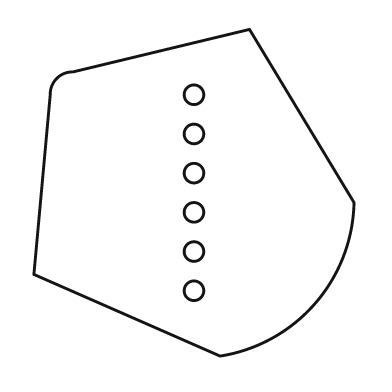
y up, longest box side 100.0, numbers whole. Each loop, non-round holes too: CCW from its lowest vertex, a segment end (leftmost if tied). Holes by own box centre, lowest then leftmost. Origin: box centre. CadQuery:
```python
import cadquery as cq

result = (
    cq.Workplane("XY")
    .moveTo(8.0, -50.0)
    .threePointArc((37.0, -34.0), (49.0, -3.0))
    .lineTo(17.0, 50.0)
    .lineTo(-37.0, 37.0)
    .threePointArc((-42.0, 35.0), (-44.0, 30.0))
    .lineTo(-49.0, -25.0)
    .close()
    .moveTo(0.0, -30.0)
    .circle(3.0)
    .moveTo(0.0, -18.0)
    .circle(3.0)
    .moveTo(0.0, -6.0)
    .circle(3.0)
    .moveTo(0.0, 6.0)
    .circle(3.0)
    .moveTo(0.0, 18.0)
    .circle(3.0)
    .moveTo(0.0, 30.0)
    .circle(3.0)
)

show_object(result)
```